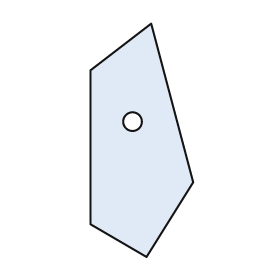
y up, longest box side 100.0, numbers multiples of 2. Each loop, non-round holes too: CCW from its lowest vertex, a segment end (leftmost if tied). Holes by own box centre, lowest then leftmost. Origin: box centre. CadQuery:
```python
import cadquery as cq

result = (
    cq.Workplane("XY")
    .moveTo(2.0, -50.0)
    .lineTo(22.0, -18.0)
    .lineTo(4.0, 50.0)
    .lineTo(-22.0, 30.0)
    .lineTo(-22.0, -36.0)
    .close()
    .moveTo(-4.0, 8.0)
    .circle(4.0)
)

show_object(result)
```